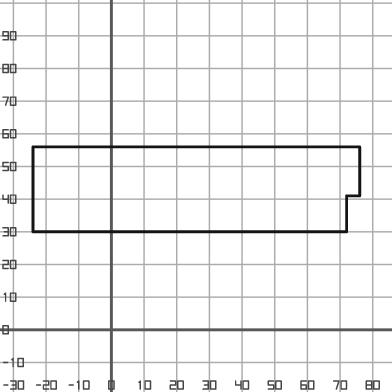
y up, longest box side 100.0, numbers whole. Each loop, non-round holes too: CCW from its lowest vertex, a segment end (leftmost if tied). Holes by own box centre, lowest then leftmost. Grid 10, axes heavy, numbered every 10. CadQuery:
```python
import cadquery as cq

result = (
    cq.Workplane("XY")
    .moveTo(-24.0, 30.0)
    .lineTo(72.0, 30.0)
    .lineTo(72.0, 41.0)
    .lineTo(76.0, 41.0)
    .lineTo(76.0, 56.0)
    .lineTo(-24.0, 56.0)
    .close()
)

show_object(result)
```